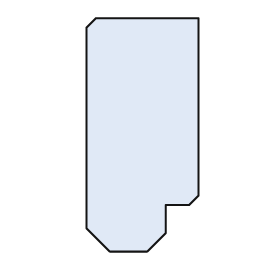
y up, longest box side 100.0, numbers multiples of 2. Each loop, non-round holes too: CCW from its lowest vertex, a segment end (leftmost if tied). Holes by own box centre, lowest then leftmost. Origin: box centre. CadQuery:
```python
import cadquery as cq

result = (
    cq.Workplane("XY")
    .moveTo(-14.0, -50.0)
    .lineTo(2.0, -50.0)
    .lineTo(10.0, -42.0)
    .lineTo(10.0, -30.0)
    .lineTo(20.0, -30.0)
    .lineTo(24.0, -26.0)
    .lineTo(24.0, 50.0)
    .lineTo(-20.0, 50.0)
    .lineTo(-24.0, 46.0)
    .lineTo(-24.0, -40.0)
    .close()
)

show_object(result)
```